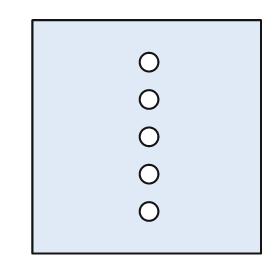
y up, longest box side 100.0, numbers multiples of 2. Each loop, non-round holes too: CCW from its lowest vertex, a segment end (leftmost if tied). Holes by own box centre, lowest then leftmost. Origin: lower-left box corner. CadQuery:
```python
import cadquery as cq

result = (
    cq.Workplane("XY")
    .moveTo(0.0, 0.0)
    .lineTo(98.0, 0.0)
    .lineTo(98.0, 100.0)
    .lineTo(0.0, 100.0)
    .close()
    .moveTo(50.0, 18.0)
    .circle(4.0)
    .moveTo(50.0, 34.0)
    .circle(4.0)
    .moveTo(50.0, 50.0)
    .circle(4.0)
    .moveTo(50.0, 66.0)
    .circle(4.0)
    .moveTo(50.0, 82.0)
    .circle(4.0)
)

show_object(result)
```